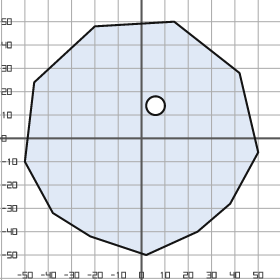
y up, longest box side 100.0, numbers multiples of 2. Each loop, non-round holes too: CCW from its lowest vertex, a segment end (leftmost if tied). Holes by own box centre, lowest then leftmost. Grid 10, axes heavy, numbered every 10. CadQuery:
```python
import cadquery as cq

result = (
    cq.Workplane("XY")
    .moveTo(2.0, -50.0)
    .lineTo(24.0, -40.0)
    .lineTo(38.0, -28.0)
    .lineTo(50.0, -6.0)
    .lineTo(42.0, 28.0)
    .lineTo(14.0, 50.0)
    .lineTo(-20.0, 48.0)
    .lineTo(-46.0, 24.0)
    .lineTo(-50.0, -10.0)
    .lineTo(-38.0, -32.0)
    .lineTo(-22.0, -42.0)
    .close()
    .moveTo(6.0, 14.0)
    .circle(4.0)
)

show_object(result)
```